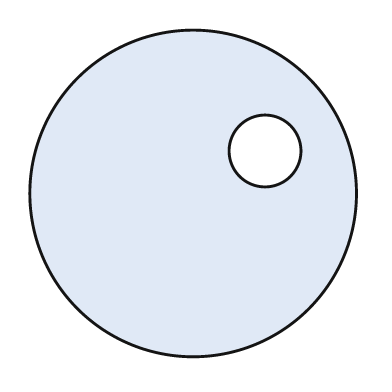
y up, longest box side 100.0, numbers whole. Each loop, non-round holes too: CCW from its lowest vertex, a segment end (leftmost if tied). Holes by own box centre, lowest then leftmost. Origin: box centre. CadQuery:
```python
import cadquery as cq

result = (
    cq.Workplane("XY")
    .moveTo(0.0, 0.0)
    .circle(50.0)
    .moveTo(22.0, 13.0)
    .circle(11.0)
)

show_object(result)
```